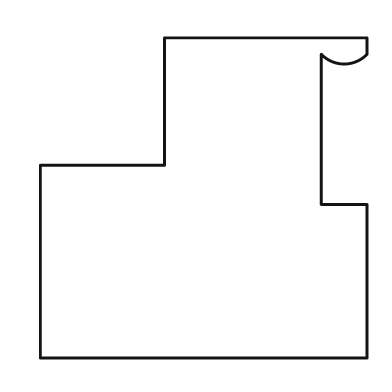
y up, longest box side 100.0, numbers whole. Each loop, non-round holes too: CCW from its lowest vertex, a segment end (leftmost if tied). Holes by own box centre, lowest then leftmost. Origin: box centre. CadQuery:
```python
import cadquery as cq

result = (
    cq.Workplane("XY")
    .moveTo(-50.0, -49.0)
    .lineTo(50.0, -49.0)
    .lineTo(50.0, -2.0)
    .lineTo(36.0, -2.0)
    .lineTo(36.0, 44.0)
    .threePointArc((43.0, 41.0), (50.0, 44.0))
    .lineTo(50.0, 49.0)
    .lineTo(-12.0, 49.0)
    .lineTo(-12.0, 10.0)
    .lineTo(-50.0, 10.0)
    .close()
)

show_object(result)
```